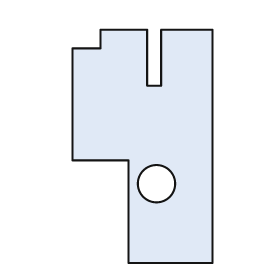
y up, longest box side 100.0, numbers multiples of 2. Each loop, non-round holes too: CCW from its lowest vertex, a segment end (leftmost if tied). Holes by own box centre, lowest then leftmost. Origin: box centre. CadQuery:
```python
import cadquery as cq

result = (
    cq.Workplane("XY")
    .moveTo(-6.0, -50.0)
    .lineTo(30.0, -50.0)
    .lineTo(30.0, 50.0)
    .lineTo(8.0, 50.0)
    .lineTo(8.0, 26.0)
    .lineTo(2.0, 26.0)
    .lineTo(2.0, 50.0)
    .lineTo(-18.0, 50.0)
    .lineTo(-18.0, 42.0)
    .lineTo(-30.0, 42.0)
    .lineTo(-30.0, -6.0)
    .lineTo(-6.0, -6.0)
    .close()
    .moveTo(6.0, -16.0)
    .circle(8.0)
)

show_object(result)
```